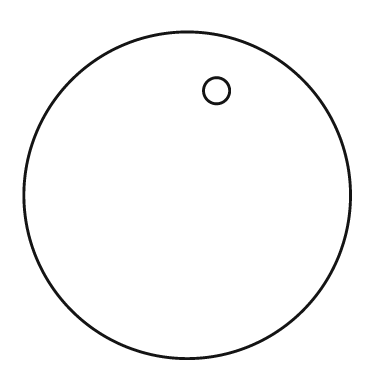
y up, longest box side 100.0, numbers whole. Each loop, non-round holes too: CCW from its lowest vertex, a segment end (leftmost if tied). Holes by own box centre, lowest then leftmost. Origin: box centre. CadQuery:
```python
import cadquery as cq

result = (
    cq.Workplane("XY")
    .moveTo(0.0, 0.0)
    .circle(50.0)
    .moveTo(9.0, 32.0)
    .circle(4.0)
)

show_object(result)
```